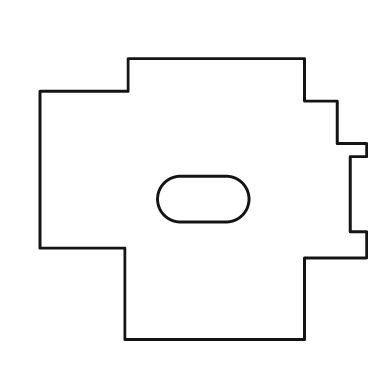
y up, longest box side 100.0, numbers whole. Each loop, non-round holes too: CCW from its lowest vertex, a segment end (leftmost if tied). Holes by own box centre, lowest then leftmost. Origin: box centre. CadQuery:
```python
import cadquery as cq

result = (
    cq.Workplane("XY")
    .moveTo(-24.0, -43.0)
    .lineTo(31.0, -43.0)
    .lineTo(31.0, -18.0)
    .lineTo(50.0, -18.0)
    .lineTo(50.0, -10.0)
    .lineTo(45.0, -10.0)
    .lineTo(45.0, 13.0)
    .lineTo(50.0, 13.0)
    .lineTo(50.0, 17.0)
    .lineTo(41.0, 17.0)
    .lineTo(41.0, 30.0)
    .lineTo(31.0, 30.0)
    .lineTo(31.0, 43.0)
    .lineTo(-23.0, 43.0)
    .lineTo(-23.0, 33.0)
    .lineTo(-50.0, 33.0)
    .lineTo(-50.0, -15.0)
    .lineTo(-24.0, -15.0)
    .close()
    .moveTo(-7.0, -7.0)
    .lineTo(7.0, -7.0)
    .threePointArc((14.0, 0.0), (7.0, 7.0))
    .lineTo(-7.0, 7.0)
    .threePointArc((-14.0, 0.0), (-7.0, -7.0))
    .close()
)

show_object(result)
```